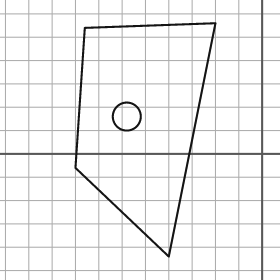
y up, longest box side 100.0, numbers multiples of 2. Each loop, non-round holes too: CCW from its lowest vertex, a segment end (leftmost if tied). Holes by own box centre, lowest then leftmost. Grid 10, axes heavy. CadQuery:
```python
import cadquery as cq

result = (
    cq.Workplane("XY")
    .moveTo(-40.0, -44.0)
    .lineTo(-20.0, 56.0)
    .lineTo(-76.0, 54.0)
    .lineTo(-80.0, -6.0)
    .close()
    .moveTo(-58.0, 16.0)
    .circle(6.0)
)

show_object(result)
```